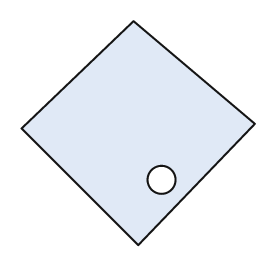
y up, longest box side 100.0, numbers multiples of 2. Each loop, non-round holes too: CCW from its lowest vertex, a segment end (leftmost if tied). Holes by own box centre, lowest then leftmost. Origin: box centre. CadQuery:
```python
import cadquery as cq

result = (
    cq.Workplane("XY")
    .moveTo(0.0, -48.0)
    .lineTo(50.0, 4.0)
    .lineTo(-2.0, 48.0)
    .lineTo(-50.0, 2.0)
    .close()
    .moveTo(10.0, -20.0)
    .circle(6.0)
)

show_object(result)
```